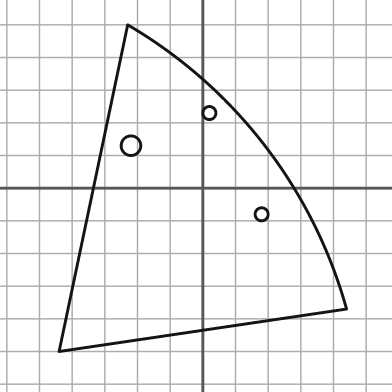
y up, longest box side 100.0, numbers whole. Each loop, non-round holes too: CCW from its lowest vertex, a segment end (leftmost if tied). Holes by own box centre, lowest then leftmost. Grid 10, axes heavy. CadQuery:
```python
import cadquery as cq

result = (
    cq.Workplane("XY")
    .moveTo(-44.0, -50.0)
    .lineTo(44.0, -37.0)
    .threePointArc((19.0, 13.0), (-23.0, 50.0))
    .close()
    .moveTo(18.0, -8.0)
    .circle(2.0)
    .moveTo(-22.0, 13.0)
    .circle(3.0)
    .moveTo(2.0, 23.0)
    .circle(2.0)
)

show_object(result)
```